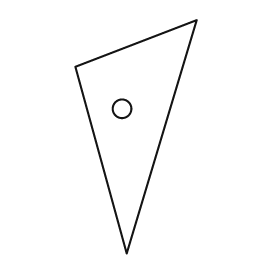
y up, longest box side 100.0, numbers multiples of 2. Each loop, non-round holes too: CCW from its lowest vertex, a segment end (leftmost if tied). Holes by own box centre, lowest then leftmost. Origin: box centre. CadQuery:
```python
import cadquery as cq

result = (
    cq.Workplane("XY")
    .moveTo(-4.0, -50.0)
    .lineTo(26.0, 50.0)
    .lineTo(-26.0, 30.0)
    .close()
    .moveTo(-6.0, 12.0)
    .circle(4.0)
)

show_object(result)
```